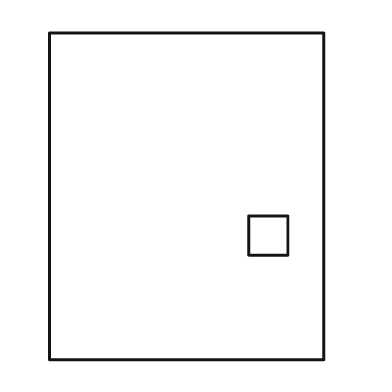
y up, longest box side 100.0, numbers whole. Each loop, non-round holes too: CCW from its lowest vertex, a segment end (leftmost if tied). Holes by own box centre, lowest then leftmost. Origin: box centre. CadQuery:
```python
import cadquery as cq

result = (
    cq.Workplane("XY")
    .moveTo(-42.0, -50.0)
    .lineTo(42.0, -50.0)
    .lineTo(42.0, 50.0)
    .lineTo(-42.0, 50.0)
    .close()
    .moveTo(19.0, -18.0)
    .lineTo(31.0, -18.0)
    .lineTo(31.0, -6.0)
    .lineTo(19.0, -6.0)
    .close()
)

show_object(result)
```